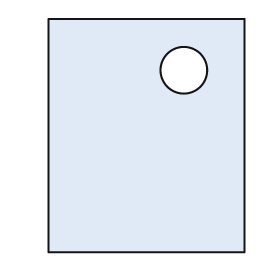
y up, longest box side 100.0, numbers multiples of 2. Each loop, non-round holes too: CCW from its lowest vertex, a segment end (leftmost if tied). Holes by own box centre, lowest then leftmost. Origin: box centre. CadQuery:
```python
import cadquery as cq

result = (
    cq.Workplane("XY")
    .moveTo(-42.0, -50.0)
    .lineTo(42.0, -50.0)
    .lineTo(42.0, 50.0)
    .lineTo(-42.0, 50.0)
    .close()
    .moveTo(16.0, 28.0)
    .circle(10.0)
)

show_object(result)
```